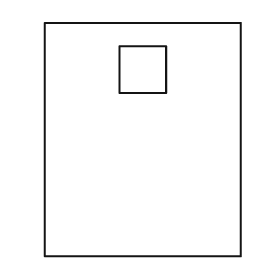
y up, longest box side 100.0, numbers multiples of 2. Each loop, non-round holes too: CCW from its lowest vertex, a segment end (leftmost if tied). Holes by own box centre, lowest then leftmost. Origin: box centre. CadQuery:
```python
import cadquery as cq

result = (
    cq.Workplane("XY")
    .moveTo(-42.0, -50.0)
    .lineTo(42.0, -50.0)
    .lineTo(42.0, 50.0)
    .lineTo(-42.0, 50.0)
    .close()
    .moveTo(-10.0, 20.0)
    .lineTo(10.0, 20.0)
    .lineTo(10.0, 40.0)
    .lineTo(-10.0, 40.0)
    .close()
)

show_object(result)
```